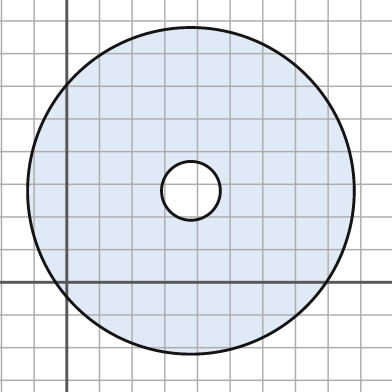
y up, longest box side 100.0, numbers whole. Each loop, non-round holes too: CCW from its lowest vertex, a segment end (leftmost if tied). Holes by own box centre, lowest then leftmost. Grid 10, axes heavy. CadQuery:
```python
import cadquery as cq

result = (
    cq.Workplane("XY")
    .moveTo(38.0, 28.0)
    .circle(50.0)
    .moveTo(38.0, 28.0)
    .circle(9.0)
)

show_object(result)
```